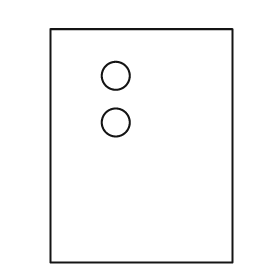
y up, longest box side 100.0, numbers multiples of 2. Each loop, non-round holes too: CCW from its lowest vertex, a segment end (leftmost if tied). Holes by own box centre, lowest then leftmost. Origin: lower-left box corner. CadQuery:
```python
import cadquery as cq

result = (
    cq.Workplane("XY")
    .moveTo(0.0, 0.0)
    .lineTo(78.0, 0.0)
    .lineTo(78.0, 100.0)
    .lineTo(0.0, 100.0)
    .close()
    .moveTo(28.0, 60.0)
    .circle(6.0)
    .moveTo(28.0, 80.0)
    .circle(6.0)
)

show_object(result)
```